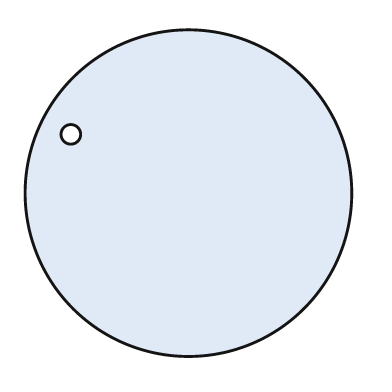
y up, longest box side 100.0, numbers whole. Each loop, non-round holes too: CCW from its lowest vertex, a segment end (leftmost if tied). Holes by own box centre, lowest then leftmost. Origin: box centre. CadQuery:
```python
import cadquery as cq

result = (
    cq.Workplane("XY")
    .moveTo(0.0, 0.0)
    .circle(50.0)
    .moveTo(-36.0, 18.0)
    .circle(3.0)
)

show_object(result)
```